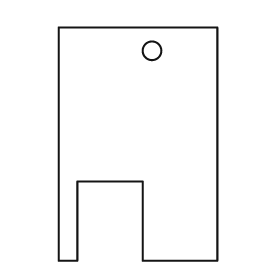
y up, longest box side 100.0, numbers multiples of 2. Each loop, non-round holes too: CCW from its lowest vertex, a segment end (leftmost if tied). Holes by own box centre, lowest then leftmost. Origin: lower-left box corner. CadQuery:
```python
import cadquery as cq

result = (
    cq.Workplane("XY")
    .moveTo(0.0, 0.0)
    .lineTo(8.0, 0.0)
    .lineTo(8.0, 34.0)
    .lineTo(36.0, 34.0)
    .lineTo(36.0, 0.0)
    .lineTo(68.0, 0.0)
    .lineTo(68.0, 100.0)
    .lineTo(0.0, 100.0)
    .close()
    .moveTo(40.0, 90.0)
    .circle(4.0)
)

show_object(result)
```